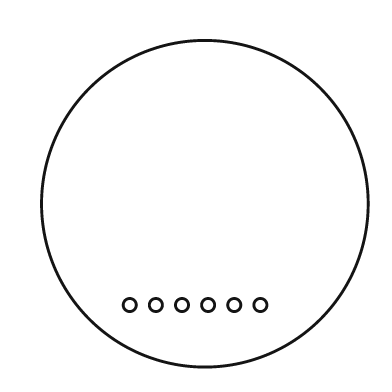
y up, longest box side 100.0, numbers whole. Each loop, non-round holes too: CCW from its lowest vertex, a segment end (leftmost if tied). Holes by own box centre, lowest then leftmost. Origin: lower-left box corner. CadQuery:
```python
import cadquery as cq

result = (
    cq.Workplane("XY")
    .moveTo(50.0, 50.0)
    .circle(50.0)
    .moveTo(27.0, 19.0)
    .circle(2.0)
    .moveTo(35.0, 19.0)
    .circle(2.0)
    .moveTo(43.0, 19.0)
    .circle(2.0)
    .moveTo(51.0, 19.0)
    .circle(2.0)
    .moveTo(59.0, 19.0)
    .circle(2.0)
    .moveTo(67.0, 19.0)
    .circle(2.0)
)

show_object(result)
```